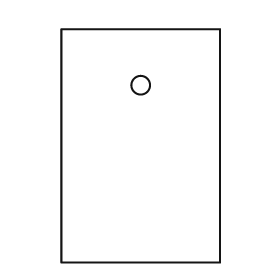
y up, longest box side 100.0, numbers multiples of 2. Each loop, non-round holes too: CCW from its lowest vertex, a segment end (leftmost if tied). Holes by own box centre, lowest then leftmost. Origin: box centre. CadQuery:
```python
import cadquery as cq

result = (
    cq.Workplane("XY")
    .moveTo(-34.0, -50.0)
    .lineTo(34.0, -50.0)
    .lineTo(34.0, 50.0)
    .lineTo(-34.0, 50.0)
    .close()
    .moveTo(0.0, 26.0)
    .circle(4.0)
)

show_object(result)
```